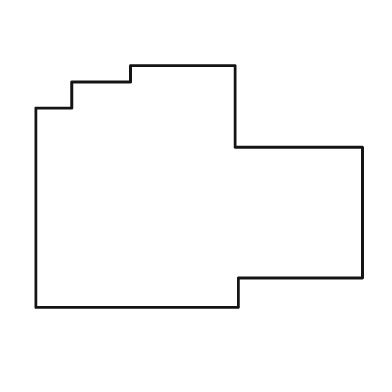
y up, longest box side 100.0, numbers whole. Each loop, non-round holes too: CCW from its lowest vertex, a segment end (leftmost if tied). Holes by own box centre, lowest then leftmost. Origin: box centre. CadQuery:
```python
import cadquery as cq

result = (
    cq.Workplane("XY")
    .moveTo(-50.0, -37.0)
    .lineTo(12.0, -37.0)
    .lineTo(12.0, -28.0)
    .lineTo(50.0, -28.0)
    .lineTo(50.0, 12.0)
    .lineTo(11.0, 12.0)
    .lineTo(11.0, 37.0)
    .lineTo(-21.0, 37.0)
    .lineTo(-21.0, 32.0)
    .lineTo(-39.0, 32.0)
    .lineTo(-39.0, 24.0)
    .lineTo(-50.0, 24.0)
    .close()
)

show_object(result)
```